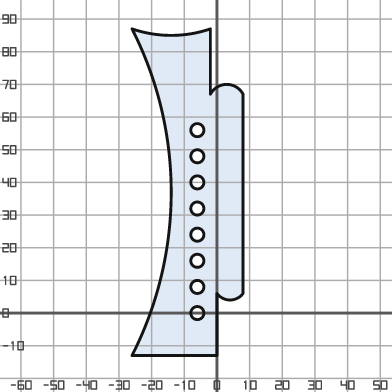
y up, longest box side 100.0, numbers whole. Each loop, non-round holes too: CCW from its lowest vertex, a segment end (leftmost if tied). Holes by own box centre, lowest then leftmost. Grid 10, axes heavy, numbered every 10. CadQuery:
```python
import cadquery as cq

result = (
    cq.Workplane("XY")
    .moveTo(-26.0, -13.0)
    .lineTo(0.0, -13.0)
    .lineTo(0.0, 6.0)
    .threePointArc((4.0, 4.0), (8.0, 6.0))
    .lineTo(8.0, 67.0)
    .threePointArc((3.0, 70.0), (-2.0, 67.0))
    .lineTo(-2.0, 87.0)
    .threePointArc((-14.0, 85.0), (-26.0, 87.0))
    .threePointArc((-14.0, 37.0), (-26.0, -13.0))
    .close()
    .moveTo(-6.0, 0.0)
    .circle(2.0)
    .moveTo(-6.0, 8.0)
    .circle(2.0)
    .moveTo(-6.0, 16.0)
    .circle(2.0)
    .moveTo(-6.0, 24.0)
    .circle(2.0)
    .moveTo(-6.0, 32.0)
    .circle(2.0)
    .moveTo(-6.0, 40.0)
    .circle(2.0)
    .moveTo(-6.0, 48.0)
    .circle(2.0)
    .moveTo(-6.0, 56.0)
    .circle(2.0)
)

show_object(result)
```